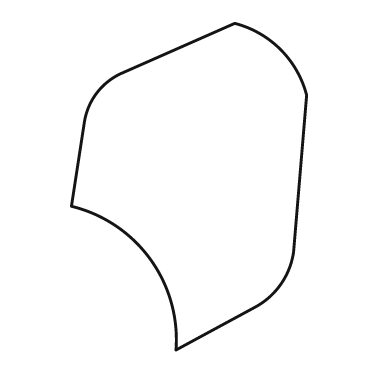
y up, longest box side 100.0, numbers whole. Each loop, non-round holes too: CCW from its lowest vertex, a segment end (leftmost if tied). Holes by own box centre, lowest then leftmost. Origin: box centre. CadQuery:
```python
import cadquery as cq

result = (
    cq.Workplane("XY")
    .moveTo(-4.0, -50.0)
    .lineTo(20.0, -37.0)
    .threePointArc((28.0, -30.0), (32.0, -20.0))
    .lineTo(36.0, 28.0)
    .threePointArc((28.0, 42.0), (14.0, 50.0))
    .lineTo(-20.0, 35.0)
    .threePointArc((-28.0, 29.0), (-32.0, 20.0))
    .lineTo(-36.0, -6.0)
    .threePointArc((-12.0, -22.0), (-4.0, -50.0))
    .close()
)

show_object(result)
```